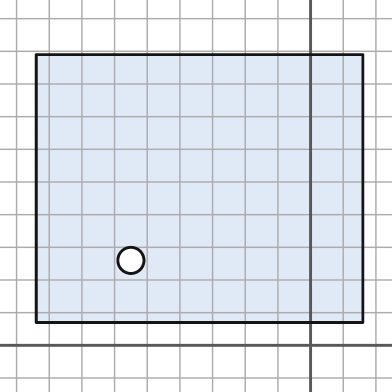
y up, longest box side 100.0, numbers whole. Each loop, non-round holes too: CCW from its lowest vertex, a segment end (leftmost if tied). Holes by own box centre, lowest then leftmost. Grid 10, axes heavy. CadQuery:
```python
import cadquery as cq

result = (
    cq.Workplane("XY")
    .moveTo(-84.0, 7.0)
    .lineTo(16.0, 7.0)
    .lineTo(16.0, 89.0)
    .lineTo(-84.0, 89.0)
    .close()
    .moveTo(-55.0, 26.0)
    .circle(4.0)
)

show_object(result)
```